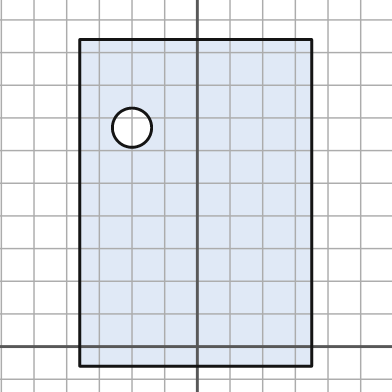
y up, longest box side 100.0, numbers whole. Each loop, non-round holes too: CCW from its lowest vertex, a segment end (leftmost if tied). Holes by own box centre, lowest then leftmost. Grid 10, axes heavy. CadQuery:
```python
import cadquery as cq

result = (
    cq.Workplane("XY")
    .moveTo(-36.0, -6.0)
    .lineTo(35.0, -6.0)
    .lineTo(35.0, 94.0)
    .lineTo(-36.0, 94.0)
    .close()
    .moveTo(-20.0, 67.0)
    .circle(6.0)
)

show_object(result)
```